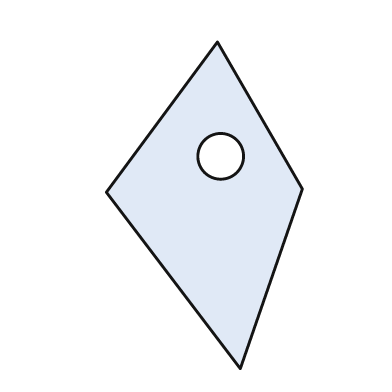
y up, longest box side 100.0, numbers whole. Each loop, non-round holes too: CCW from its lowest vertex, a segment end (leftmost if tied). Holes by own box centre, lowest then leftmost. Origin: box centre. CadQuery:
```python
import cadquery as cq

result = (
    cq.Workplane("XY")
    .moveTo(11.0, -50.0)
    .lineTo(30.0, 5.0)
    .lineTo(4.0, 50.0)
    .lineTo(-30.0, 4.0)
    .close()
    .moveTo(5.0, 15.0)
    .circle(7.0)
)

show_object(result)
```